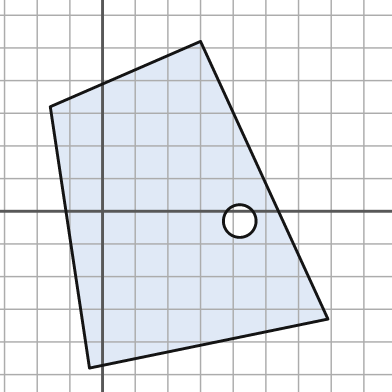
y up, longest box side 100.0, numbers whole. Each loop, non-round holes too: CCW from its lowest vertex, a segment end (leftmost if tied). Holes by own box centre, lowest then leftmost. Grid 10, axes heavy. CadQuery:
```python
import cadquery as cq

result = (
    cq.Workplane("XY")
    .moveTo(-4.0, -48.0)
    .lineTo(69.0, -33.0)
    .lineTo(30.0, 52.0)
    .lineTo(-16.0, 32.0)
    .close()
    .moveTo(42.0, -3.0)
    .circle(5.0)
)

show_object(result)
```